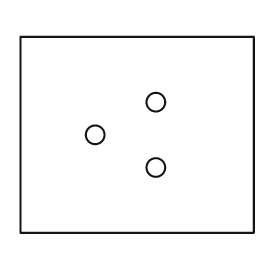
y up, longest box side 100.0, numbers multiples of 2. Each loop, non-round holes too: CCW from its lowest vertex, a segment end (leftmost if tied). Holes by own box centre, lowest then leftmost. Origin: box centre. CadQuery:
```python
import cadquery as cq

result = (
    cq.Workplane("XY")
    .moveTo(-50.0, -42.0)
    .lineTo(50.0, -42.0)
    .lineTo(50.0, 42.0)
    .lineTo(-50.0, 42.0)
    .close()
    .moveTo(8.0, -14.0)
    .circle(4.0)
    .moveTo(-18.0, 0.0)
    .circle(4.0)
    .moveTo(8.0, 14.0)
    .circle(4.0)
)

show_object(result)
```